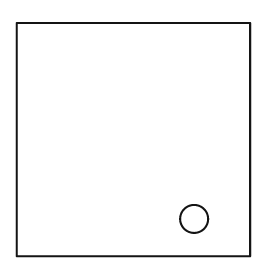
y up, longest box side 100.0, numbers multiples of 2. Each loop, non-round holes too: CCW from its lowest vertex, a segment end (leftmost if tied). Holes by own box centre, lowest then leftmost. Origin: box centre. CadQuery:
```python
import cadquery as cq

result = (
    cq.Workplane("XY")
    .moveTo(-50.0, -50.0)
    .lineTo(50.0, -50.0)
    .lineTo(50.0, 50.0)
    .lineTo(-50.0, 50.0)
    .close()
    .moveTo(26.0, -34.0)
    .circle(6.0)
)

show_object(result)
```